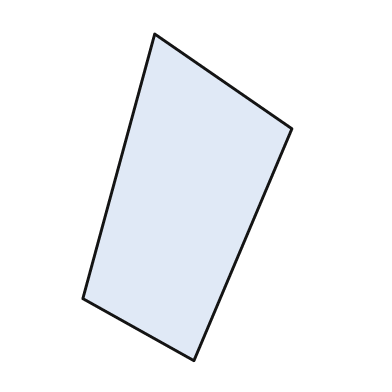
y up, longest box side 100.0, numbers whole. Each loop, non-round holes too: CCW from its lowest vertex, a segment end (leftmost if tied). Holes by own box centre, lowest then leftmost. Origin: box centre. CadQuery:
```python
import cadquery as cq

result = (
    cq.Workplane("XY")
    .moveTo(2.0, -50.0)
    .lineTo(32.0, 21.0)
    .lineTo(-10.0, 50.0)
    .lineTo(-32.0, -31.0)
    .close()
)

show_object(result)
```